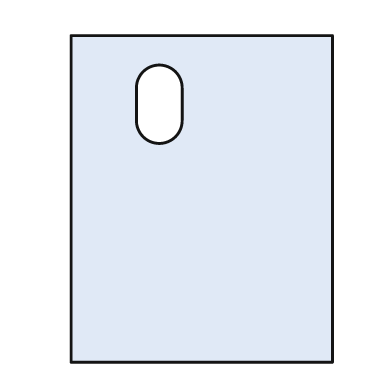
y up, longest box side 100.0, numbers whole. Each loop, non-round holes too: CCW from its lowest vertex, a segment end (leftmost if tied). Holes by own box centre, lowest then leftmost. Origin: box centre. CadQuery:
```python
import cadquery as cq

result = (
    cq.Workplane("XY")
    .moveTo(-40.0, -50.0)
    .lineTo(40.0, -50.0)
    .lineTo(40.0, 50.0)
    .lineTo(-40.0, 50.0)
    .close()
    .moveTo(-20.0, 24.0)
    .threePointArc((-13.0, 17.0), (-6.0, 24.0))
    .lineTo(-6.0, 34.0)
    .threePointArc((-13.0, 41.0), (-20.0, 34.0))
    .close()
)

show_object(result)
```